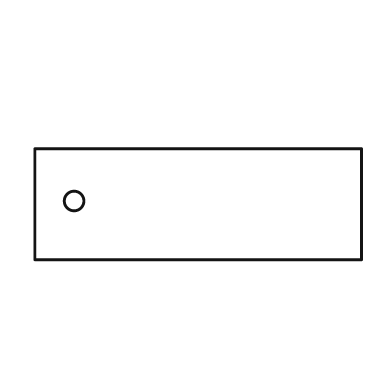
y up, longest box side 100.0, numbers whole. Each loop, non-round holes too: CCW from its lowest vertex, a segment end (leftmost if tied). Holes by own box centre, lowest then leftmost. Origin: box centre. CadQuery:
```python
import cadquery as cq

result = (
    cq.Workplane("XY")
    .moveTo(-50.0, -17.0)
    .lineTo(50.0, -17.0)
    .lineTo(50.0, 17.0)
    .lineTo(-50.0, 17.0)
    .close()
    .moveTo(-38.0, 1.0)
    .circle(3.0)
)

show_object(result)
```